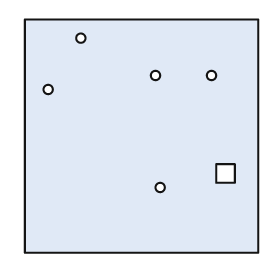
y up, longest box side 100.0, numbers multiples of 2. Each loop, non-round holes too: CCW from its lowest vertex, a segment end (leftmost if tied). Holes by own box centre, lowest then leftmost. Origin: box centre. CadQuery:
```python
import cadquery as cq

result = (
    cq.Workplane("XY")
    .moveTo(-50.0, -50.0)
    .lineTo(50.0, -50.0)
    .lineTo(50.0, 50.0)
    .lineTo(-50.0, 50.0)
    .close()
    .moveTo(8.0, -22.0)
    .circle(2.0)
    .moveTo(32.0, -20.0)
    .lineTo(40.0, -20.0)
    .lineTo(40.0, -12.0)
    .lineTo(32.0, -12.0)
    .close()
    .moveTo(-40.0, 20.0)
    .circle(2.0)
    .moveTo(6.0, 26.0)
    .circle(2.0)
    .moveTo(30.0, 26.0)
    .circle(2.0)
    .moveTo(-26.0, 42.0)
    .circle(2.0)
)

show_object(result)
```